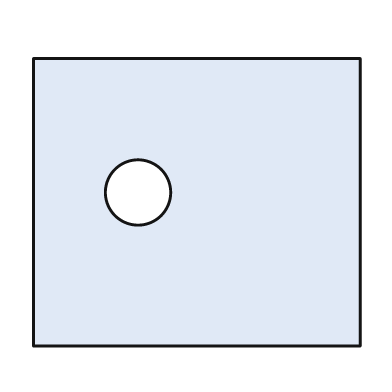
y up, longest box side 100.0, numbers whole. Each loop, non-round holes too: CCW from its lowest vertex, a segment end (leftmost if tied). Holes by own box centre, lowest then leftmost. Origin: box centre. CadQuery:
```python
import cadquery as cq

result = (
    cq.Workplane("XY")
    .moveTo(-50.0, -44.0)
    .lineTo(50.0, -44.0)
    .lineTo(50.0, 44.0)
    .lineTo(-50.0, 44.0)
    .close()
    .moveTo(-18.0, 3.0)
    .circle(10.0)
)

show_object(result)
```